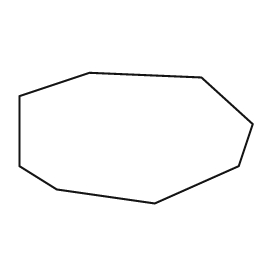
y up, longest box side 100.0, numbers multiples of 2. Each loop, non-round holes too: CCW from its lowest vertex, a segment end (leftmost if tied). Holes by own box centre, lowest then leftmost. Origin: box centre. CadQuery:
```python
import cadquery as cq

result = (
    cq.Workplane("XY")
    .moveTo(8.0, -28.0)
    .lineTo(44.0, -12.0)
    .lineTo(50.0, 6.0)
    .lineTo(28.0, 26.0)
    .lineTo(-20.0, 28.0)
    .lineTo(-50.0, 18.0)
    .lineTo(-50.0, -12.0)
    .lineTo(-34.0, -22.0)
    .close()
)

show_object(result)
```